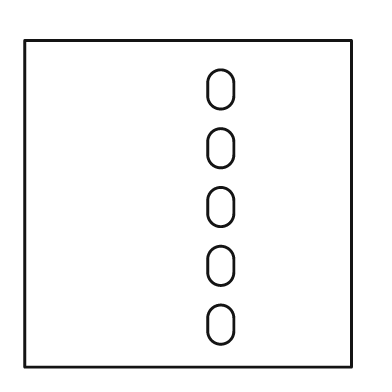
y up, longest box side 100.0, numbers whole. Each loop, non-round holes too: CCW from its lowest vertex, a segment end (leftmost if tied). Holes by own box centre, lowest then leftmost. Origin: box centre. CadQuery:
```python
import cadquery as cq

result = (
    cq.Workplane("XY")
    .moveTo(-50.0, -50.0)
    .lineTo(50.0, -50.0)
    .lineTo(50.0, 50.0)
    .lineTo(-50.0, 50.0)
    .close()
    .moveTo(6.0, -39.0)
    .threePointArc((10.0, -43.0), (14.0, -39.0))
    .lineTo(14.0, -35.0)
    .threePointArc((10.0, -31.0), (6.0, -35.0))
    .close()
    .moveTo(6.0, -21.0)
    .threePointArc((10.0, -25.0), (14.0, -21.0))
    .lineTo(14.0, -17.0)
    .threePointArc((10.0, -13.0), (6.0, -17.0))
    .close()
    .moveTo(6.0, -3.0)
    .threePointArc((10.0, -7.0), (14.0, -3.0))
    .lineTo(14.0, 1.0)
    .threePointArc((10.0, 5.0), (6.0, 1.0))
    .close()
    .moveTo(6.0, 15.0)
    .threePointArc((10.0, 11.0), (14.0, 15.0))
    .lineTo(14.0, 19.0)
    .threePointArc((10.0, 23.0), (6.0, 19.0))
    .close()
    .moveTo(6.0, 33.0)
    .threePointArc((10.0, 29.0), (14.0, 33.0))
    .lineTo(14.0, 37.0)
    .threePointArc((10.0, 41.0), (6.0, 37.0))
    .close()
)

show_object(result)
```